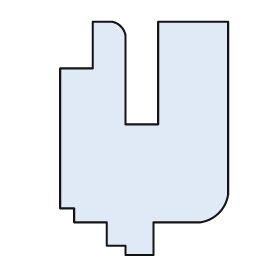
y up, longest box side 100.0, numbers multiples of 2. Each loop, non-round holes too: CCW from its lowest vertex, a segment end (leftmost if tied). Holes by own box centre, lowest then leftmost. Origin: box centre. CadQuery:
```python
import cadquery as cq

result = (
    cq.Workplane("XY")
    .moveTo(-8.0, -50.0)
    .lineTo(4.0, -50.0)
    .lineTo(4.0, -36.0)
    .lineTo(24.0, -36.0)
    .threePointArc((32.0, -32.0), (36.0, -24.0))
    .lineTo(36.0, 50.0)
    .lineTo(6.0, 50.0)
    .lineTo(6.0, 6.0)
    .lineTo(-8.0, 6.0)
    .lineTo(-8.0, 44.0)
    .threePointArc((-10.0, 48.0), (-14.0, 50.0))
    .lineTo(-22.0, 50.0)
    .lineTo(-22.0, 30.0)
    .lineTo(-36.0, 30.0)
    .lineTo(-36.0, -30.0)
    .lineTo(-30.0, -30.0)
    .lineTo(-30.0, -36.0)
    .lineTo(-16.0, -36.0)
    .lineTo(-16.0, -46.0)
    .lineTo(-8.0, -46.0)
    .close()
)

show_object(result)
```